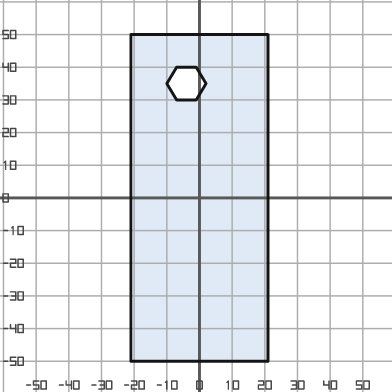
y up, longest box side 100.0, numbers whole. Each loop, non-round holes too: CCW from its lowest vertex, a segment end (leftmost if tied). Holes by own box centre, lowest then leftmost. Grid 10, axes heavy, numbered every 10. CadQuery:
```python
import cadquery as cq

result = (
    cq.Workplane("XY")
    .moveTo(-21.0, -50.0)
    .lineTo(21.0, -50.0)
    .lineTo(21.0, 50.0)
    .lineTo(-21.0, 50.0)
    .close()
    .moveTo(-7.0, 30.0)
    .lineTo(-1.0, 30.0)
    .lineTo(2.0, 35.0)
    .lineTo(-1.0, 40.0)
    .lineTo(-7.0, 40.0)
    .lineTo(-10.0, 35.0)
    .close()
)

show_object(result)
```